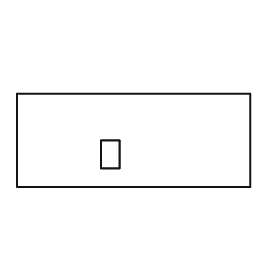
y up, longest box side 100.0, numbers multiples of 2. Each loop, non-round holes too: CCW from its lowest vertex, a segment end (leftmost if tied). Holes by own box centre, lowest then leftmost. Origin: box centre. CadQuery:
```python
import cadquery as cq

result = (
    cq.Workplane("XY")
    .moveTo(-50.0, -20.0)
    .lineTo(50.0, -20.0)
    .lineTo(50.0, 20.0)
    .lineTo(-50.0, 20.0)
    .close()
    .moveTo(-14.0, -12.0)
    .lineTo(-6.0, -12.0)
    .lineTo(-6.0, 0.0)
    .lineTo(-14.0, 0.0)
    .close()
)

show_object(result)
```